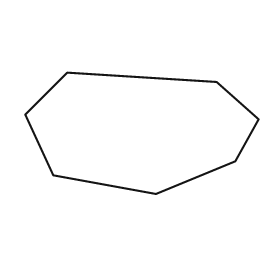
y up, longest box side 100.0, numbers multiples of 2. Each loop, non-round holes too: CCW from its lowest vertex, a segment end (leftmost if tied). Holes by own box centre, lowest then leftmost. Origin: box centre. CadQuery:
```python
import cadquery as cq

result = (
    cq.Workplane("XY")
    .moveTo(6.0, -26.0)
    .lineTo(40.0, -12.0)
    .lineTo(50.0, 6.0)
    .lineTo(32.0, 22.0)
    .lineTo(-32.0, 26.0)
    .lineTo(-50.0, 8.0)
    .lineTo(-38.0, -18.0)
    .close()
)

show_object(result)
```